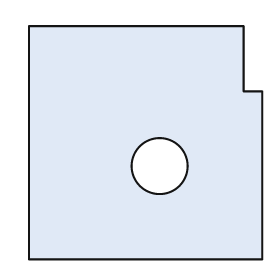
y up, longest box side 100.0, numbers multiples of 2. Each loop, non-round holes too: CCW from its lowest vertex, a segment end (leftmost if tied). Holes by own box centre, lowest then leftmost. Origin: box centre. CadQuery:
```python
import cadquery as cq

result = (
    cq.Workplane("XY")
    .moveTo(-50.0, -50.0)
    .lineTo(50.0, -50.0)
    .lineTo(50.0, 22.0)
    .lineTo(42.0, 22.0)
    .lineTo(42.0, 50.0)
    .lineTo(-50.0, 50.0)
    .close()
    .moveTo(6.0, -10.0)
    .circle(12.0)
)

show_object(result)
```